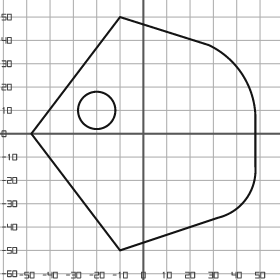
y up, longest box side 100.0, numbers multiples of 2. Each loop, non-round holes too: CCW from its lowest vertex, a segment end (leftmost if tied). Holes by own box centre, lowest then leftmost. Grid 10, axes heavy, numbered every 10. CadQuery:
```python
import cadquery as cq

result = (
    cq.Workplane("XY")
    .moveTo(-10.0, -50.0)
    .lineTo(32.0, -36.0)
    .threePointArc((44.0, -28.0), (48.0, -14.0))
    .lineTo(48.0, 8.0)
    .threePointArc((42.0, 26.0), (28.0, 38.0))
    .lineTo(-10.0, 50.0)
    .lineTo(-48.0, 0.0)
    .close()
    .moveTo(-20.0, 10.0)
    .circle(8.0)
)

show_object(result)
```